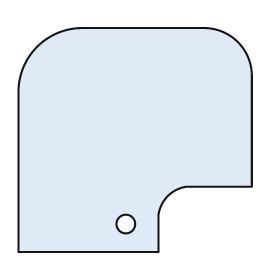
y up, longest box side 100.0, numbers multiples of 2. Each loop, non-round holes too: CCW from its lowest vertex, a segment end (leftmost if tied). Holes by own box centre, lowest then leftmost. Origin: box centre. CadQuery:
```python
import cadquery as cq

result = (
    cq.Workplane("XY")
    .moveTo(-50.0, -48.0)
    .lineTo(10.0, -48.0)
    .lineTo(10.0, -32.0)
    .threePointArc((14.0, -24.0), (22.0, -20.0))
    .lineTo(50.0, -20.0)
    .lineTo(50.0, 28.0)
    .threePointArc((44.0, 42.0), (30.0, 48.0))
    .lineTo(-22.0, 48.0)
    .threePointArc((-42.0, 40.0), (-50.0, 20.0))
    .close()
    .moveTo(-4.0, -36.0)
    .circle(4.0)
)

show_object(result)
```